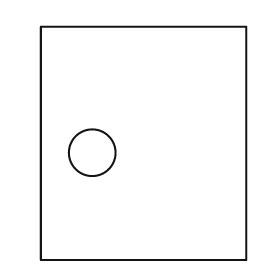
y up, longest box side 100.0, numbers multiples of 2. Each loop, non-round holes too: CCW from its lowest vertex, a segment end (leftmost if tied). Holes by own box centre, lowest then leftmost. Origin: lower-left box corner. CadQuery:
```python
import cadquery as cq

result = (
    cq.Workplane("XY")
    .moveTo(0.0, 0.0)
    .lineTo(88.0, 0.0)
    .lineTo(88.0, 100.0)
    .lineTo(0.0, 100.0)
    .close()
    .moveTo(22.0, 46.0)
    .circle(10.0)
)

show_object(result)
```